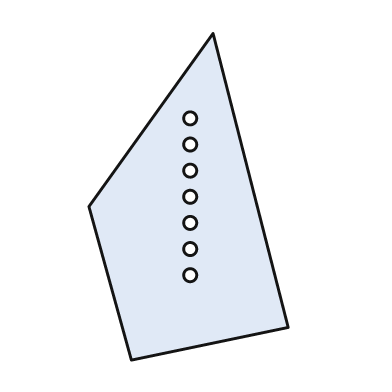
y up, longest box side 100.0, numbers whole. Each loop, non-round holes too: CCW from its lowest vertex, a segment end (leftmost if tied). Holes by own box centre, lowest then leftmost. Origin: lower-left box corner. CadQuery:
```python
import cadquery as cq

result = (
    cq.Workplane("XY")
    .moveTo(13.0, 0.0)
    .lineTo(61.0, 10.0)
    .lineTo(38.0, 100.0)
    .lineTo(0.0, 47.0)
    .close()
    .moveTo(31.0, 26.0)
    .circle(2.0)
    .moveTo(31.0, 34.0)
    .circle(2.0)
    .moveTo(31.0, 42.0)
    .circle(2.0)
    .moveTo(31.0, 50.0)
    .circle(2.0)
    .moveTo(31.0, 58.0)
    .circle(2.0)
    .moveTo(31.0, 66.0)
    .circle(2.0)
    .moveTo(31.0, 74.0)
    .circle(2.0)
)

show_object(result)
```